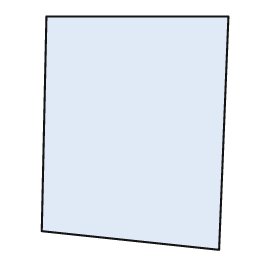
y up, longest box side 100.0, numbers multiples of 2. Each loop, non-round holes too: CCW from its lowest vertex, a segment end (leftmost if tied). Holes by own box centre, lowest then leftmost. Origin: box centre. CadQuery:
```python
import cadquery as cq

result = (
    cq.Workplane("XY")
    .moveTo(36.0, -50.0)
    .lineTo(40.0, 50.0)
    .lineTo(-38.0, 50.0)
    .lineTo(-40.0, -42.0)
    .close()
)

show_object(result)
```